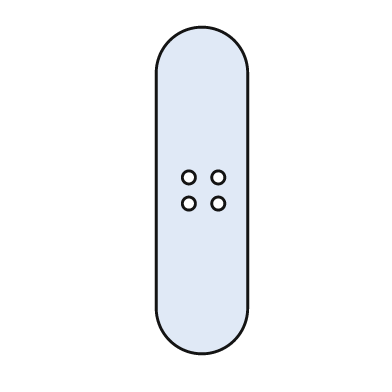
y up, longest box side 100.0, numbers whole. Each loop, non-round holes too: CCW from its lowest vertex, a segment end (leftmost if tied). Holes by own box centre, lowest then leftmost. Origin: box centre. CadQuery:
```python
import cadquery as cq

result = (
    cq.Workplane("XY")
    .moveTo(-14.0, -36.0)
    .threePointArc((0.0, -50.0), (14.0, -36.0))
    .lineTo(14.0, 36.0)
    .threePointArc((0.0, 50.0), (-14.0, 36.0))
    .close()
    .moveTo(-4.0, -4.0)
    .circle(2.0)
    .moveTo(5.0, -4.0)
    .circle(2.0)
    .moveTo(-4.0, 4.0)
    .circle(2.0)
    .moveTo(5.0, 4.0)
    .circle(2.0)
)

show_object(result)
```